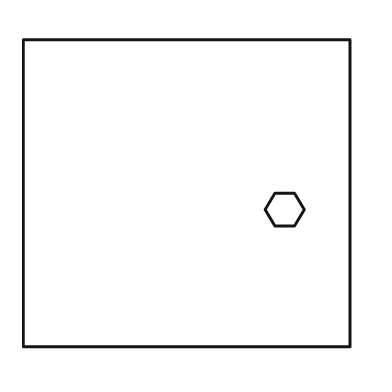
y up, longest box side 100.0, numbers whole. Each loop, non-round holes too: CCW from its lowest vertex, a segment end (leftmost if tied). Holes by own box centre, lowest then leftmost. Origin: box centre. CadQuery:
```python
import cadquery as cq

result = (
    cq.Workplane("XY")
    .moveTo(-50.0, -47.0)
    .lineTo(50.0, -47.0)
    .lineTo(50.0, 47.0)
    .lineTo(-50.0, 47.0)
    .close()
    .moveTo(27.0, -10.0)
    .lineTo(33.0, -10.0)
    .lineTo(36.0, -5.0)
    .lineTo(33.0, 0.0)
    .lineTo(27.0, 0.0)
    .lineTo(24.0, -5.0)
    .close()
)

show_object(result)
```